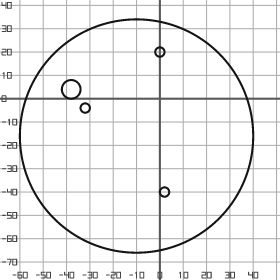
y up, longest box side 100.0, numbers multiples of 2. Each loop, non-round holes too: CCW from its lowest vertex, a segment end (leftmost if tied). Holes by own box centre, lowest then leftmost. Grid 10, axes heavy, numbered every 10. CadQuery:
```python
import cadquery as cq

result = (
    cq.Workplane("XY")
    .moveTo(-10.0, -16.0)
    .circle(50.0)
    .moveTo(2.0, -40.0)
    .circle(2.0)
    .moveTo(-32.0, -4.0)
    .circle(2.0)
    .moveTo(-38.0, 4.0)
    .circle(4.0)
    .moveTo(0.0, 20.0)
    .circle(2.0)
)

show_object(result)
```